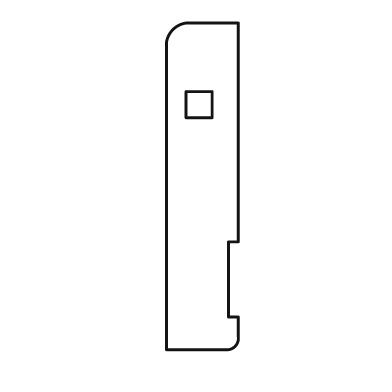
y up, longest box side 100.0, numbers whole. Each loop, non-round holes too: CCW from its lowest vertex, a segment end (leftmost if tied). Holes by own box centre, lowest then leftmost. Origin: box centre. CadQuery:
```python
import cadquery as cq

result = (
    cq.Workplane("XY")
    .moveTo(-11.0, -50.0)
    .lineTo(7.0, -50.0)
    .threePointArc((10.0, -49.0), (11.0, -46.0))
    .lineTo(11.0, -40.0)
    .lineTo(8.0, -40.0)
    .lineTo(8.0, -17.0)
    .lineTo(11.0, -17.0)
    .lineTo(11.0, 50.0)
    .lineTo(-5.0, 50.0)
    .threePointArc((-9.0, 48.0), (-11.0, 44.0))
    .close()
    .moveTo(-5.0, 21.0)
    .lineTo(3.0, 21.0)
    .lineTo(3.0, 29.0)
    .lineTo(-5.0, 29.0)
    .close()
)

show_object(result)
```